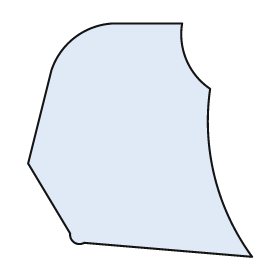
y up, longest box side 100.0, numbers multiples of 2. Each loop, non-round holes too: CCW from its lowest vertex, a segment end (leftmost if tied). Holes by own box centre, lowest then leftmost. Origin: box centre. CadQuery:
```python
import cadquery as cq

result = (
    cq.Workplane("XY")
    .moveTo(48.0, -50.0)
    .threePointArc((32.0, -16.0), (30.0, 22.0))
    .threePointArc((20.0, 34.0), (18.0, 50.0))
    .lineTo(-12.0, 50.0)
    .threePointArc((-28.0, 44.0), (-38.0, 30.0))
    .lineTo(-48.0, -10.0)
    .lineTo(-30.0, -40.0)
    .threePointArc((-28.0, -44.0), (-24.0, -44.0))
    .close()
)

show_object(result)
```